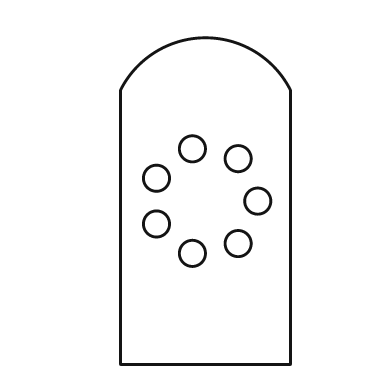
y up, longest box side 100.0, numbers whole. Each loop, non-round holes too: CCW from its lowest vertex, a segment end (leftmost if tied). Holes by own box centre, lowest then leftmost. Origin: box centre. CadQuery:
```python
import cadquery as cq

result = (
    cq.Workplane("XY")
    .moveTo(-26.0, -50.0)
    .lineTo(26.0, -50.0)
    .lineTo(26.0, 34.0)
    .threePointArc((0.0, 50.0), (-26.0, 34.0))
    .close()
    .moveTo(-4.0, -16.0)
    .circle(4.0)
    .moveTo(10.0, -13.0)
    .circle(4.0)
    .moveTo(-15.0, -7.0)
    .circle(4.0)
    .moveTo(16.0, 0.0)
    .circle(4.0)
    .moveTo(-15.0, 7.0)
    .circle(4.0)
    .moveTo(10.0, 13.0)
    .circle(4.0)
    .moveTo(-4.0, 16.0)
    .circle(4.0)
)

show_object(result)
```